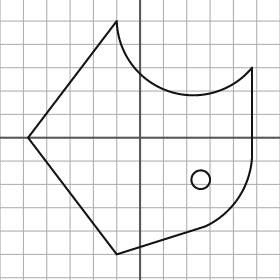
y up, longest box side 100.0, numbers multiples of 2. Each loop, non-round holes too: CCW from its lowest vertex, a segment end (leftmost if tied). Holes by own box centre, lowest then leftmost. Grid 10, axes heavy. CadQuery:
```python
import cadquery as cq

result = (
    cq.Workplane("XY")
    .moveTo(-10.0, -50.0)
    .lineTo(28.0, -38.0)
    .threePointArc((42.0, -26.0), (48.0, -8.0))
    .lineTo(48.0, 30.0)
    .threePointArc((12.0, 20.0), (-10.0, 50.0))
    .lineTo(-48.0, 0.0)
    .close()
    .moveTo(26.0, -18.0)
    .circle(4.0)
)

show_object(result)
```